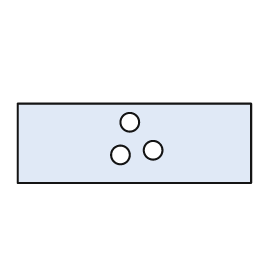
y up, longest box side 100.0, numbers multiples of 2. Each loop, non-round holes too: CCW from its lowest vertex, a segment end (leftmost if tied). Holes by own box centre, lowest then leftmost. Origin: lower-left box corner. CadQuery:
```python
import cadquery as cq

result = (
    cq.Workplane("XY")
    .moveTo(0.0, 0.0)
    .lineTo(100.0, 0.0)
    .lineTo(100.0, 34.0)
    .lineTo(0.0, 34.0)
    .close()
    .moveTo(44.0, 12.0)
    .circle(4.0)
    .moveTo(58.0, 14.0)
    .circle(4.0)
    .moveTo(48.0, 26.0)
    .circle(4.0)
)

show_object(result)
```